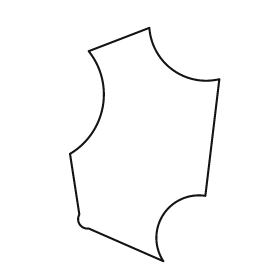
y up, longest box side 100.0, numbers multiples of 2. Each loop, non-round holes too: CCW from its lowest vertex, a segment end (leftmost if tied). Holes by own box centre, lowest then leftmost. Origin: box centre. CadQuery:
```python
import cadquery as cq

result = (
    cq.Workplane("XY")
    .moveTo(8.0, -50.0)
    .threePointArc((8.0, -30.0), (26.0, -22.0))
    .lineTo(32.0, 28.0)
    .threePointArc((12.0, 32.0), (2.0, 50.0))
    .lineTo(-24.0, 40.0)
    .threePointArc((-18.0, 16.0), (-32.0, -4.0))
    .lineTo(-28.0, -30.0)
    .threePointArc((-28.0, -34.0), (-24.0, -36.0))
    .close()
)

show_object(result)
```